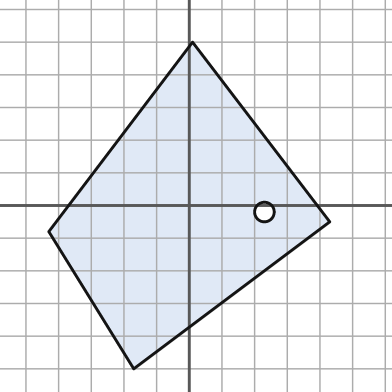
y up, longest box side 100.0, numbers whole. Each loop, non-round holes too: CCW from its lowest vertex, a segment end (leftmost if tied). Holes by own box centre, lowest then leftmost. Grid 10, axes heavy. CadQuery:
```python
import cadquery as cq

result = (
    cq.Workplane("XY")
    .moveTo(-17.0, -50.0)
    .lineTo(43.0, -5.0)
    .lineTo(1.0, 50.0)
    .lineTo(-43.0, -8.0)
    .close()
    .moveTo(23.0, -2.0)
    .circle(3.0)
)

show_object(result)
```